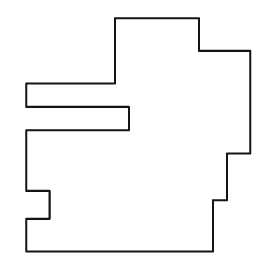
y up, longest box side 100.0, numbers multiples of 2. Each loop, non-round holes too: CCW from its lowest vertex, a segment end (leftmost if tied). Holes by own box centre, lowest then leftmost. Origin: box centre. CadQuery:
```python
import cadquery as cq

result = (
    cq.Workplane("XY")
    .moveTo(-48.0, -50.0)
    .lineTo(32.0, -50.0)
    .lineTo(32.0, -28.0)
    .lineTo(38.0, -28.0)
    .lineTo(38.0, -8.0)
    .lineTo(48.0, -8.0)
    .lineTo(48.0, 36.0)
    .lineTo(26.0, 36.0)
    .lineTo(26.0, 50.0)
    .lineTo(-10.0, 50.0)
    .lineTo(-10.0, 22.0)
    .lineTo(-48.0, 22.0)
    .lineTo(-48.0, 12.0)
    .lineTo(-4.0, 12.0)
    .lineTo(-4.0, 2.0)
    .lineTo(-48.0, 2.0)
    .lineTo(-48.0, -24.0)
    .lineTo(-38.0, -24.0)
    .lineTo(-38.0, -36.0)
    .lineTo(-48.0, -36.0)
    .close()
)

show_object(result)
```